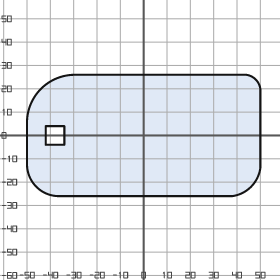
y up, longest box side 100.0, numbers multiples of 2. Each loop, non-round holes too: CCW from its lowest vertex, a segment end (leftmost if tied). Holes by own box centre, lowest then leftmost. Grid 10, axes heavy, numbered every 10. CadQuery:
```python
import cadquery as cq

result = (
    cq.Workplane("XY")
    .moveTo(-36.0, -26.0)
    .lineTo(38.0, -26.0)
    .threePointArc((46.0, -22.0), (50.0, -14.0))
    .lineTo(50.0, 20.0)
    .threePointArc((48.0, 24.0), (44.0, 26.0))
    .lineTo(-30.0, 26.0)
    .threePointArc((-44.0, 20.0), (-50.0, 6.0))
    .lineTo(-50.0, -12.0)
    .threePointArc((-46.0, -22.0), (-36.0, -26.0))
    .close()
    .moveTo(-42.0, -4.0)
    .lineTo(-34.0, -4.0)
    .lineTo(-34.0, 4.0)
    .lineTo(-42.0, 4.0)
    .close()
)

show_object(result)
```